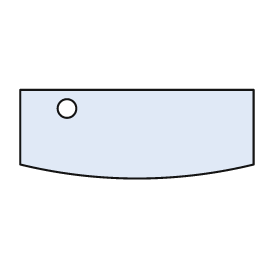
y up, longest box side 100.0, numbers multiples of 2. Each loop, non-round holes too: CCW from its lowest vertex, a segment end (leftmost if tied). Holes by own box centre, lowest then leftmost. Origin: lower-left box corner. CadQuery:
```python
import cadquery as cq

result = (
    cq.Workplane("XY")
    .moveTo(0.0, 6.0)
    .threePointArc((50.0, 0.0), (100.0, 6.0))
    .lineTo(100.0, 38.0)
    .lineTo(0.0, 38.0)
    .close()
    .moveTo(20.0, 30.0)
    .circle(4.0)
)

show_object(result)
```